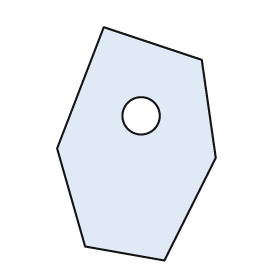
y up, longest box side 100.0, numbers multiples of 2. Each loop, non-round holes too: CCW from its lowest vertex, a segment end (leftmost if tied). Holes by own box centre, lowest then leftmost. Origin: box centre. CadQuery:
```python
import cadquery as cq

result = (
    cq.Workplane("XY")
    .moveTo(12.0, -50.0)
    .lineTo(34.0, -6.0)
    .lineTo(28.0, 36.0)
    .lineTo(-14.0, 50.0)
    .lineTo(-34.0, -2.0)
    .lineTo(-22.0, -44.0)
    .close()
    .moveTo(2.0, 12.0)
    .circle(8.0)
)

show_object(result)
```